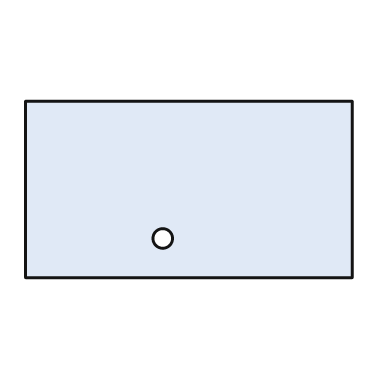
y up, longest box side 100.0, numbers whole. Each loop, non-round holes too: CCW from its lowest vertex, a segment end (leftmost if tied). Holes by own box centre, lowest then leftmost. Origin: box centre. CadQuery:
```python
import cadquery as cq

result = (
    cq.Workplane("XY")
    .moveTo(-50.0, -27.0)
    .lineTo(50.0, -27.0)
    .lineTo(50.0, 27.0)
    .lineTo(-50.0, 27.0)
    .close()
    .moveTo(-8.0, -15.0)
    .circle(3.0)
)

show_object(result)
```